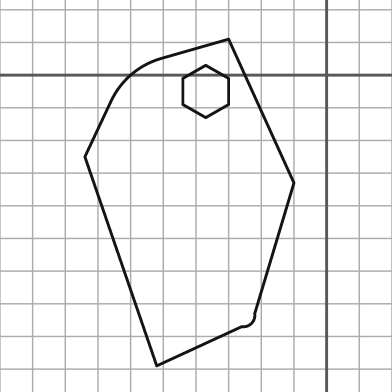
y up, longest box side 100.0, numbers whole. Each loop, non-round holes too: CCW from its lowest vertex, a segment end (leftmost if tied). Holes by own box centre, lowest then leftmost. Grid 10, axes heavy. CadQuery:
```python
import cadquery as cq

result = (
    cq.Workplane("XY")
    .moveTo(-52.0, -89.0)
    .lineTo(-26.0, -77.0)
    .threePointArc((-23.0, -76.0), (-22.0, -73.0))
    .lineTo(-10.0, -33.0)
    .lineTo(-30.0, 11.0)
    .lineTo(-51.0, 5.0)
    .threePointArc((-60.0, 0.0), (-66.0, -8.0))
    .lineTo(-74.0, -25.0)
    .close()
    .moveTo(-37.0, -13.0)
    .lineTo(-30.0, -9.0)
    .lineTo(-30.0, -1.0)
    .lineTo(-37.0, 3.0)
    .lineTo(-44.0, -1.0)
    .lineTo(-44.0, -9.0)
    .close()
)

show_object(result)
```